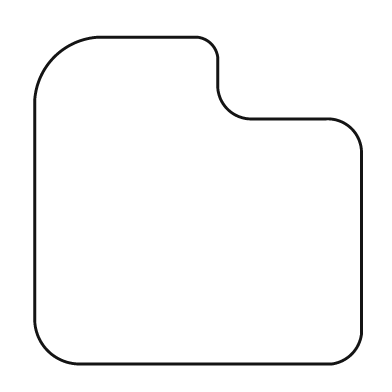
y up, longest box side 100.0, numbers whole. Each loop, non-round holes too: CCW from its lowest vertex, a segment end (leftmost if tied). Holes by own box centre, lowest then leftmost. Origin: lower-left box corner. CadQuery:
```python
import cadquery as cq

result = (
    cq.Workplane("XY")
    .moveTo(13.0, 0.0)
    .lineTo(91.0, 0.0)
    .threePointArc((97.0, 3.0), (100.0, 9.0))
    .lineTo(100.0, 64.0)
    .threePointArc((97.0, 72.0), (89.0, 75.0))
    .lineTo(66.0, 75.0)
    .threePointArc((59.0, 78.0), (56.0, 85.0))
    .lineTo(56.0, 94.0)
    .threePointArc((54.0, 98.0), (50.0, 100.0))
    .lineTo(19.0, 100.0)
    .threePointArc((6.0, 94.0), (0.0, 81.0))
    .lineTo(0.0, 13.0)
    .threePointArc((4.0, 4.0), (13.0, 0.0))
    .close()
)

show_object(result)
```